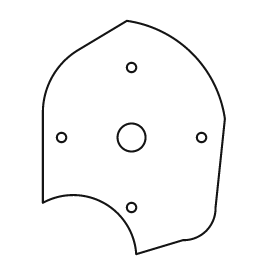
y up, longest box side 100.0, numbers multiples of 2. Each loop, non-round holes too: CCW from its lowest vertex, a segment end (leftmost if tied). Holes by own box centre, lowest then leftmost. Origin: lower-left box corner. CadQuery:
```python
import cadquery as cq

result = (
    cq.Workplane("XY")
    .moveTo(40.0, 0.0)
    .lineTo(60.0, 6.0)
    .threePointArc((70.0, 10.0), (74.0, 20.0))
    .lineTo(78.0, 58.0)
    .threePointArc((64.0, 86.0), (36.0, 100.0))
    .lineTo(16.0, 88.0)
    .threePointArc((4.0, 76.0), (0.0, 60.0))
    .lineTo(0.0, 22.0)
    .threePointArc((26.0, 22.0), (40.0, 0.0))
    .close()
    .moveTo(38.0, 20.0)
    .circle(2.0)
    .moveTo(8.0, 50.0)
    .circle(2.0)
    .moveTo(38.0, 50.0)
    .circle(6.0)
    .moveTo(68.0, 50.0)
    .circle(2.0)
    .moveTo(38.0, 80.0)
    .circle(2.0)
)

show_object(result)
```